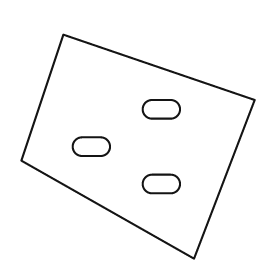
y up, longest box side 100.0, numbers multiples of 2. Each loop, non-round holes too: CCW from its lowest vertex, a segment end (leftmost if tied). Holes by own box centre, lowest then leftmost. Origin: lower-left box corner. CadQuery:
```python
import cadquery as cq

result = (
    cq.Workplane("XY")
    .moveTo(74.0, 0.0)
    .lineTo(100.0, 68.0)
    .lineTo(18.0, 96.0)
    .lineTo(0.0, 42.0)
    .close()
    .moveTo(56.0, 28.0)
    .lineTo(64.0, 28.0)
    .threePointArc((68.0, 32.0), (64.0, 36.0))
    .lineTo(56.0, 36.0)
    .threePointArc((52.0, 32.0), (56.0, 28.0))
    .close()
    .moveTo(26.0, 44.0)
    .lineTo(34.0, 44.0)
    .threePointArc((38.0, 48.0), (34.0, 52.0))
    .lineTo(26.0, 52.0)
    .threePointArc((22.0, 48.0), (26.0, 44.0))
    .close()
    .moveTo(56.0, 60.0)
    .lineTo(64.0, 60.0)
    .threePointArc((68.0, 64.0), (64.0, 68.0))
    .lineTo(56.0, 68.0)
    .threePointArc((52.0, 64.0), (56.0, 60.0))
    .close()
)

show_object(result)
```